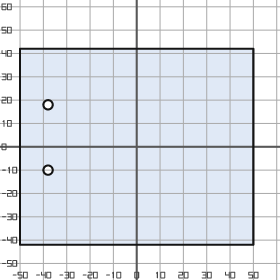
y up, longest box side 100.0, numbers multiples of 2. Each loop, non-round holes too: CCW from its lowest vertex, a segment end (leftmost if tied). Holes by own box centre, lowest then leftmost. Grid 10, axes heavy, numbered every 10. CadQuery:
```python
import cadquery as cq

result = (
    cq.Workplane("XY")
    .moveTo(-50.0, -42.0)
    .lineTo(50.0, -42.0)
    .lineTo(50.0, 42.0)
    .lineTo(-50.0, 42.0)
    .close()
    .moveTo(-38.0, -10.0)
    .circle(2.0)
    .moveTo(-38.0, 18.0)
    .circle(2.0)
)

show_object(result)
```